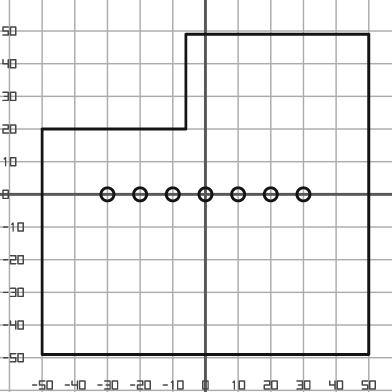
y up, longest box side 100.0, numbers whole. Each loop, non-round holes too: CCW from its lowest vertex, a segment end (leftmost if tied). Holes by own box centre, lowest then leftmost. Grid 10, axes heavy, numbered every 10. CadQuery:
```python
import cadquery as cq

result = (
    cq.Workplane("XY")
    .moveTo(-50.0, -49.0)
    .lineTo(50.0, -49.0)
    .lineTo(50.0, 49.0)
    .lineTo(-6.0, 49.0)
    .lineTo(-6.0, 20.0)
    .lineTo(-50.0, 20.0)
    .close()
    .moveTo(-30.0, 0.0)
    .circle(2.0)
    .moveTo(-20.0, 0.0)
    .circle(2.0)
    .moveTo(-10.0, 0.0)
    .circle(2.0)
    .moveTo(0.0, 0.0)
    .circle(2.0)
    .moveTo(10.0, 0.0)
    .circle(2.0)
    .moveTo(20.0, 0.0)
    .circle(2.0)
    .moveTo(30.0, 0.0)
    .circle(2.0)
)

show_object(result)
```